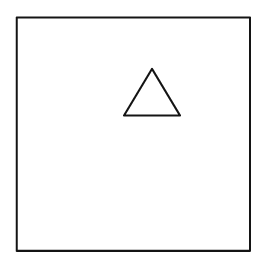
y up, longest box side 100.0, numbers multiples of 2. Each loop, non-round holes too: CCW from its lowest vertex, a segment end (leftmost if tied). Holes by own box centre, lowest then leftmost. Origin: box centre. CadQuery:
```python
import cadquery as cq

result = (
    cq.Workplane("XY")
    .moveTo(-50.0, -50.0)
    .lineTo(50.0, -50.0)
    .lineTo(50.0, 50.0)
    .lineTo(-50.0, 50.0)
    .close()
    .moveTo(-4.0, 8.0)
    .lineTo(20.0, 8.0)
    .lineTo(8.0, 28.0)
    .close()
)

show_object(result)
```